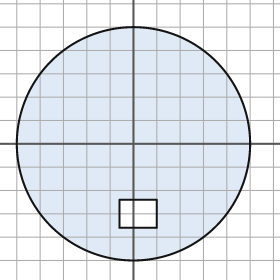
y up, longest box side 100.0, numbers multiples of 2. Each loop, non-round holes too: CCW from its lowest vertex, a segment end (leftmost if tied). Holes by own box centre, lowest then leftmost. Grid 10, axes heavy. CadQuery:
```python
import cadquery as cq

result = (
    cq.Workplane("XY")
    .moveTo(0.0, 0.0)
    .circle(50.0)
    .moveTo(-6.0, -36.0)
    .lineTo(10.0, -36.0)
    .lineTo(10.0, -24.0)
    .lineTo(-6.0, -24.0)
    .close()
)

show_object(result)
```